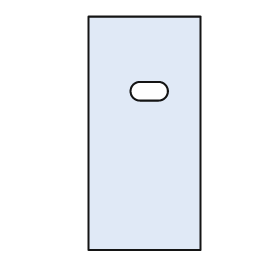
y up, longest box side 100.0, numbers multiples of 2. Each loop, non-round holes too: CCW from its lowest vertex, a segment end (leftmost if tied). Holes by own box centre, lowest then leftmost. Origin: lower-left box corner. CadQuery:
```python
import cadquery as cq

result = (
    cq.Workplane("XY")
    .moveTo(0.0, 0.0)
    .lineTo(48.0, 0.0)
    .lineTo(48.0, 100.0)
    .lineTo(0.0, 100.0)
    .close()
    .moveTo(22.0, 64.0)
    .lineTo(30.0, 64.0)
    .threePointArc((34.0, 68.0), (30.0, 72.0))
    .lineTo(22.0, 72.0)
    .threePointArc((18.0, 68.0), (22.0, 64.0))
    .close()
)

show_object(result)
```